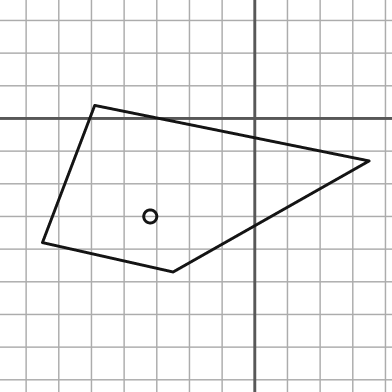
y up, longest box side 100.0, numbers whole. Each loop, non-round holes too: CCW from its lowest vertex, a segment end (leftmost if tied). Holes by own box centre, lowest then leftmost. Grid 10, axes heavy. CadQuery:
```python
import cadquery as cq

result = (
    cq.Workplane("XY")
    .moveTo(-25.0, -47.0)
    .lineTo(35.0, -13.0)
    .lineTo(-49.0, 4.0)
    .lineTo(-65.0, -38.0)
    .close()
    .moveTo(-32.0, -30.0)
    .circle(2.0)
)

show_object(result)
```